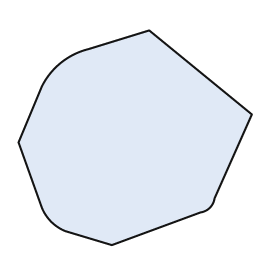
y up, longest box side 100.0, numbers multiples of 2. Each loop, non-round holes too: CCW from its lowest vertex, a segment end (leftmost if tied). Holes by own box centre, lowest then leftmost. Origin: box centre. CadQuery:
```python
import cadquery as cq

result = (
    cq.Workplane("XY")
    .moveTo(-10.0, -46.0)
    .lineTo(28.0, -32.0)
    .threePointArc((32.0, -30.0), (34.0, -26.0))
    .lineTo(50.0, 10.0)
    .lineTo(6.0, 46.0)
    .lineTo(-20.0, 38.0)
    .threePointArc((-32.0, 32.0), (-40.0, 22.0))
    .lineTo(-50.0, -2.0)
    .lineTo(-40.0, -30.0)
    .threePointArc((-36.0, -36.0), (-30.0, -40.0))
    .close()
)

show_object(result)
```